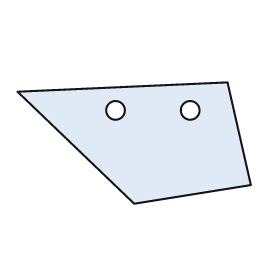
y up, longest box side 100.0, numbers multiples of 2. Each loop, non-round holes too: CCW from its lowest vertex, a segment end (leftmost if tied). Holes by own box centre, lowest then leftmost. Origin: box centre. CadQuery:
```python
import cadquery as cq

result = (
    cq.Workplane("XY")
    .moveTo(0.0, -26.0)
    .lineTo(50.0, -18.0)
    .lineTo(40.0, 26.0)
    .lineTo(-50.0, 22.0)
    .close()
    .moveTo(-8.0, 14.0)
    .circle(4.0)
    .moveTo(24.0, 14.0)
    .circle(4.0)
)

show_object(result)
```